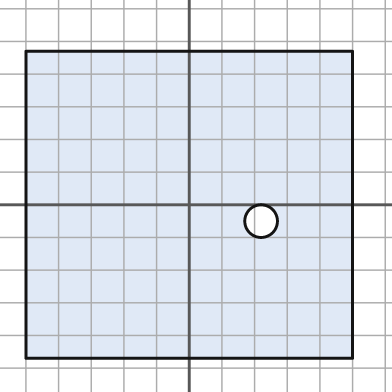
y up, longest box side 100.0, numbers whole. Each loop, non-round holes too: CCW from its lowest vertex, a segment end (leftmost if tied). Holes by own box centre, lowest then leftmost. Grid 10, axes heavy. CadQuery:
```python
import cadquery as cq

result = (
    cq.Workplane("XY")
    .moveTo(-50.0, -47.0)
    .lineTo(50.0, -47.0)
    .lineTo(50.0, 47.0)
    .lineTo(-50.0, 47.0)
    .close()
    .moveTo(22.0, -5.0)
    .circle(5.0)
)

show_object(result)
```